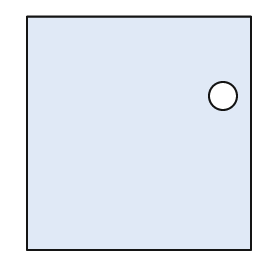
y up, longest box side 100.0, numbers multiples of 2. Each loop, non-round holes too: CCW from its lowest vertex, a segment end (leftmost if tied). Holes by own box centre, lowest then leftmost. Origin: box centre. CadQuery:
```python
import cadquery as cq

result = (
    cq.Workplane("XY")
    .moveTo(-48.0, -50.0)
    .lineTo(48.0, -50.0)
    .lineTo(48.0, 50.0)
    .lineTo(-48.0, 50.0)
    .close()
    .moveTo(36.0, 16.0)
    .circle(6.0)
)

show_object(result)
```